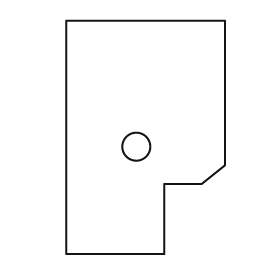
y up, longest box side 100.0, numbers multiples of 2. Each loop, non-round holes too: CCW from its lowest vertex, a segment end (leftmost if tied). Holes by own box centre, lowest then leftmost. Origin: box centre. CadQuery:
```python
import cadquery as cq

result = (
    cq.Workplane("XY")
    .moveTo(-34.0, -50.0)
    .lineTo(8.0, -50.0)
    .lineTo(8.0, -20.0)
    .lineTo(24.0, -20.0)
    .lineTo(34.0, -12.0)
    .lineTo(34.0, 50.0)
    .lineTo(-34.0, 50.0)
    .close()
    .moveTo(-4.0, -4.0)
    .circle(6.0)
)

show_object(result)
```